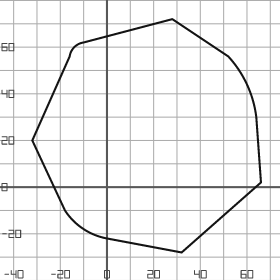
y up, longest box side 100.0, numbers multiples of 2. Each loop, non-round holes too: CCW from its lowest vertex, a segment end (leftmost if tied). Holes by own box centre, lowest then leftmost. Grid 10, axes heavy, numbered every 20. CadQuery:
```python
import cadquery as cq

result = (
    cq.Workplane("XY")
    .moveTo(32.0, -28.0)
    .lineTo(66.0, 2.0)
    .lineTo(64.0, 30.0)
    .threePointArc((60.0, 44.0), (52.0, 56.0))
    .lineTo(28.0, 72.0)
    .lineTo(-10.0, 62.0)
    .threePointArc((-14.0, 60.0), (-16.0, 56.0))
    .lineTo(-32.0, 20.0)
    .lineTo(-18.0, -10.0)
    .threePointArc((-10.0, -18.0), (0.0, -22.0))
    .close()
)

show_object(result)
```